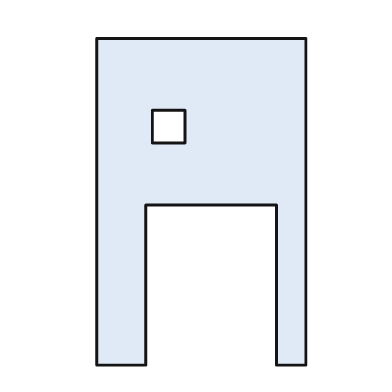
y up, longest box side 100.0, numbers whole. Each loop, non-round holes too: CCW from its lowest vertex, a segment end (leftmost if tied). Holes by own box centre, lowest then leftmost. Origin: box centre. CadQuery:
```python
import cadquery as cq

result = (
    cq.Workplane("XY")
    .moveTo(-32.0, -50.0)
    .lineTo(-17.0, -50.0)
    .lineTo(-17.0, -1.0)
    .lineTo(23.0, -1.0)
    .lineTo(23.0, -50.0)
    .lineTo(32.0, -50.0)
    .lineTo(32.0, 50.0)
    .lineTo(-32.0, 50.0)
    .close()
    .moveTo(-15.0, 18.0)
    .lineTo(-5.0, 18.0)
    .lineTo(-5.0, 28.0)
    .lineTo(-15.0, 28.0)
    .close()
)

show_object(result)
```